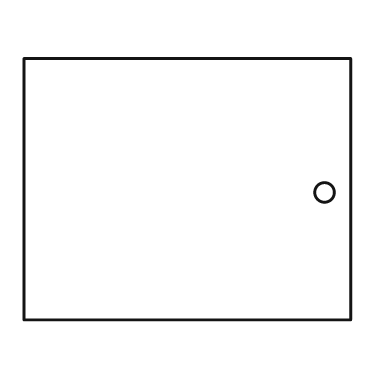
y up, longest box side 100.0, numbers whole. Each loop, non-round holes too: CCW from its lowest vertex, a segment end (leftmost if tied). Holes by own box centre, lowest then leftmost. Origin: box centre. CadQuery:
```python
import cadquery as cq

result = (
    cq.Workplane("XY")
    .moveTo(-50.0, -40.0)
    .lineTo(50.0, -40.0)
    .lineTo(50.0, 40.0)
    .lineTo(-50.0, 40.0)
    .close()
    .moveTo(42.0, -1.0)
    .circle(3.0)
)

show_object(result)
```